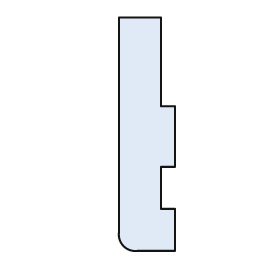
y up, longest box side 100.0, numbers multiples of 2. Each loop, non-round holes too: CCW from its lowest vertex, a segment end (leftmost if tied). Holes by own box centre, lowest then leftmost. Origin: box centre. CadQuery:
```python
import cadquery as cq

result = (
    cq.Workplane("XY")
    .moveTo(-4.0, -50.0)
    .lineTo(12.0, -50.0)
    .lineTo(12.0, -32.0)
    .lineTo(6.0, -32.0)
    .lineTo(6.0, -14.0)
    .lineTo(12.0, -14.0)
    .lineTo(12.0, 12.0)
    .lineTo(6.0, 12.0)
    .lineTo(6.0, 50.0)
    .lineTo(-12.0, 50.0)
    .lineTo(-12.0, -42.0)
    .threePointArc((-10.0, -48.0), (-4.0, -50.0))
    .close()
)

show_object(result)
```